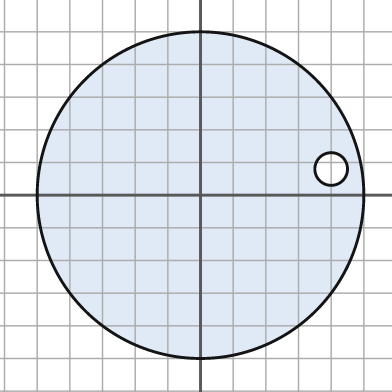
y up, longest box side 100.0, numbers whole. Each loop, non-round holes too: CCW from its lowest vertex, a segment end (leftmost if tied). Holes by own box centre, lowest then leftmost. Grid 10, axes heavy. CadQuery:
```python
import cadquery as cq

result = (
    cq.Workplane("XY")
    .moveTo(0.0, 0.0)
    .circle(50.0)
    .moveTo(40.0, 8.0)
    .circle(5.0)
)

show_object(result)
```